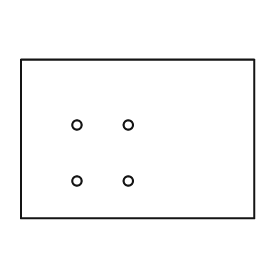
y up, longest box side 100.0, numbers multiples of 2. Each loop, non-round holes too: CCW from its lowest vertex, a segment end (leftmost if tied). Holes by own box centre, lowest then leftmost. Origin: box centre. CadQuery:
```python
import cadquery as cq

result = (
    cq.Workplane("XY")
    .moveTo(-50.0, -34.0)
    .lineTo(50.0, -34.0)
    .lineTo(50.0, 34.0)
    .lineTo(-50.0, 34.0)
    .close()
    .moveTo(-26.0, -18.0)
    .circle(2.0)
    .moveTo(-4.0, -18.0)
    .circle(2.0)
    .moveTo(-26.0, 6.0)
    .circle(2.0)
    .moveTo(-4.0, 6.0)
    .circle(2.0)
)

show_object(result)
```